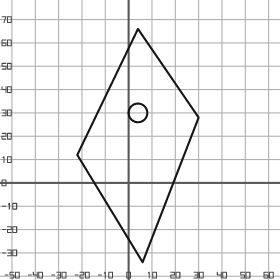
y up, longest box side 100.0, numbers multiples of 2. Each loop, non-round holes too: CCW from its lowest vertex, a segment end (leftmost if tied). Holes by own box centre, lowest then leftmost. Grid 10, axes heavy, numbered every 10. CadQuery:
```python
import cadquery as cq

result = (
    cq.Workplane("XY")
    .moveTo(6.0, -34.0)
    .lineTo(30.0, 28.0)
    .lineTo(4.0, 66.0)
    .lineTo(-22.0, 12.0)
    .close()
    .moveTo(4.0, 30.0)
    .circle(4.0)
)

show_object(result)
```